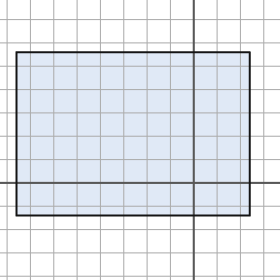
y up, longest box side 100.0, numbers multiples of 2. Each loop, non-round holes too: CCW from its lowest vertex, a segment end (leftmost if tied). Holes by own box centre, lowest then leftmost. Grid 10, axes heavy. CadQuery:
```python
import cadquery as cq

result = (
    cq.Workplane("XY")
    .moveTo(-76.0, -14.0)
    .lineTo(24.0, -14.0)
    .lineTo(24.0, 56.0)
    .lineTo(-76.0, 56.0)
    .close()
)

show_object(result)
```